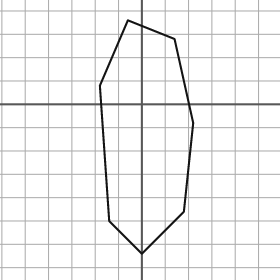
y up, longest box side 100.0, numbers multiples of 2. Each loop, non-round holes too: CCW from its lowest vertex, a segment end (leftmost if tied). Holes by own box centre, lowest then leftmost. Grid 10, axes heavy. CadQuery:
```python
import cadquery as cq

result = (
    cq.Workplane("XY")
    .moveTo(0.0, -64.0)
    .lineTo(18.0, -46.0)
    .lineTo(22.0, -8.0)
    .lineTo(14.0, 28.0)
    .lineTo(-6.0, 36.0)
    .lineTo(-18.0, 8.0)
    .lineTo(-14.0, -50.0)
    .close()
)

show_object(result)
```